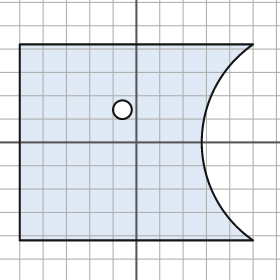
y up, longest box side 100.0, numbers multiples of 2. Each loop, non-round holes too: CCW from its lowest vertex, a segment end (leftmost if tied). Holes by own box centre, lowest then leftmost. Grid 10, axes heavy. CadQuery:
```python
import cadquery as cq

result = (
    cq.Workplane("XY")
    .moveTo(-50.0, -42.0)
    .lineTo(50.0, -42.0)
    .threePointArc((28.0, 0.0), (50.0, 42.0))
    .lineTo(-50.0, 42.0)
    .close()
    .moveTo(-6.0, 14.0)
    .circle(4.0)
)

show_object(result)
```